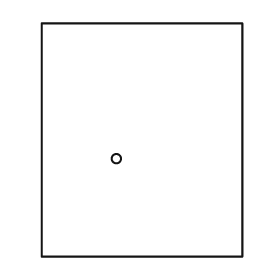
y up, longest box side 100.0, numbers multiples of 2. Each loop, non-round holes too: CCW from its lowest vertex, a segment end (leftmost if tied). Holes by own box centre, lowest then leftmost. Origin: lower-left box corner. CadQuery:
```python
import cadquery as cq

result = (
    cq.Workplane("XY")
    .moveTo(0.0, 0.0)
    .lineTo(86.0, 0.0)
    .lineTo(86.0, 100.0)
    .lineTo(0.0, 100.0)
    .close()
    .moveTo(32.0, 42.0)
    .circle(2.0)
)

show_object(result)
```